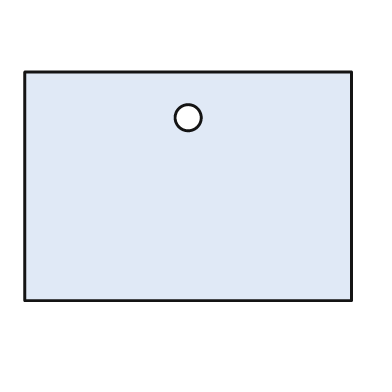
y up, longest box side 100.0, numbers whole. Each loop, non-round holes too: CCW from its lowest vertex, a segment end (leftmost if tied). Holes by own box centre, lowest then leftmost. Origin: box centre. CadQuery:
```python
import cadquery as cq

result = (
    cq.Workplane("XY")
    .moveTo(-50.0, -35.0)
    .lineTo(50.0, -35.0)
    .lineTo(50.0, 35.0)
    .lineTo(-50.0, 35.0)
    .close()
    .moveTo(0.0, 21.0)
    .circle(4.0)
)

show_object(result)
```